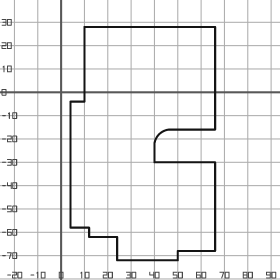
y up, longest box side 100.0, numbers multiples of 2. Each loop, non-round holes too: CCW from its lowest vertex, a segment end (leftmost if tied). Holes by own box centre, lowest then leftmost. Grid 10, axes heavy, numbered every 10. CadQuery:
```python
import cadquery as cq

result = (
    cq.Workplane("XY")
    .moveTo(24.0, -72.0)
    .lineTo(50.0, -72.0)
    .lineTo(50.0, -68.0)
    .lineTo(66.0, -68.0)
    .lineTo(66.0, -30.0)
    .lineTo(40.0, -30.0)
    .lineTo(40.0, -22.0)
    .threePointArc((42.0, -18.0), (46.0, -16.0))
    .lineTo(66.0, -16.0)
    .lineTo(66.0, 28.0)
    .lineTo(10.0, 28.0)
    .lineTo(10.0, -4.0)
    .lineTo(4.0, -4.0)
    .lineTo(4.0, -58.0)
    .lineTo(12.0, -58.0)
    .lineTo(12.0, -62.0)
    .lineTo(24.0, -62.0)
    .close()
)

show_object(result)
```